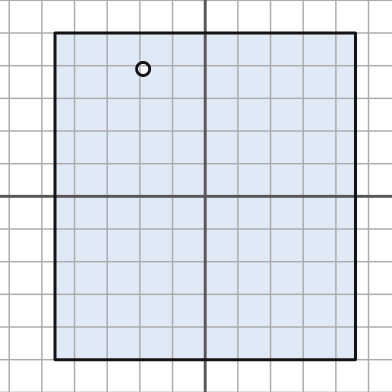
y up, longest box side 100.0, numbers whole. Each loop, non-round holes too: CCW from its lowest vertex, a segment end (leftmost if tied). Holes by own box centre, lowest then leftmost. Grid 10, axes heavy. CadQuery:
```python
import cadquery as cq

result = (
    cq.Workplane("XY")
    .moveTo(-46.0, -50.0)
    .lineTo(46.0, -50.0)
    .lineTo(46.0, 50.0)
    .lineTo(-46.0, 50.0)
    .close()
    .moveTo(-19.0, 39.0)
    .circle(2.0)
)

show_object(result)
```